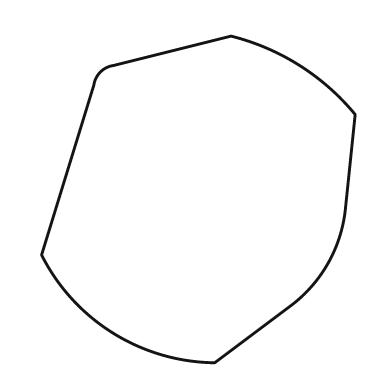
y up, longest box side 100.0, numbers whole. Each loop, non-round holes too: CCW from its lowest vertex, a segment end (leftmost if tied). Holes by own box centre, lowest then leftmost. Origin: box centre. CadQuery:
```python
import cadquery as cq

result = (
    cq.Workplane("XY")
    .moveTo(5.0, -50.0)
    .lineTo(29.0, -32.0)
    .threePointArc((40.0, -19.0), (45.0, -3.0))
    .lineTo(48.0, 26.0)
    .threePointArc((31.0, 41.0), (10.0, 50.0))
    .lineTo(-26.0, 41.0)
    .threePointArc((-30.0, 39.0), (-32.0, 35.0))
    .lineTo(-48.0, -17.0)
    .threePointArc((-26.0, -41.0), (5.0, -50.0))
    .close()
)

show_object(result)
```